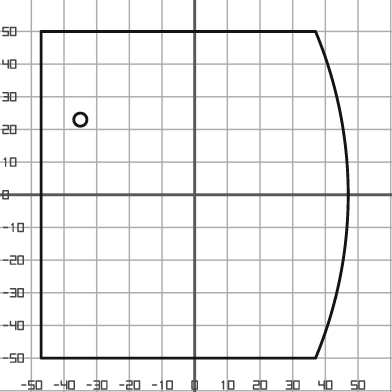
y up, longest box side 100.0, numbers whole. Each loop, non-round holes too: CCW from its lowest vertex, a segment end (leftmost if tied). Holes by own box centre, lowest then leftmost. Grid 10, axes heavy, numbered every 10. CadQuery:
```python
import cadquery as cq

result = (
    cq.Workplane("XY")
    .moveTo(-47.0, -50.0)
    .lineTo(37.0, -50.0)
    .threePointArc((47.0, 0.0), (37.0, 50.0))
    .lineTo(-47.0, 50.0)
    .close()
    .moveTo(-35.0, 23.0)
    .circle(2.0)
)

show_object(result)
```